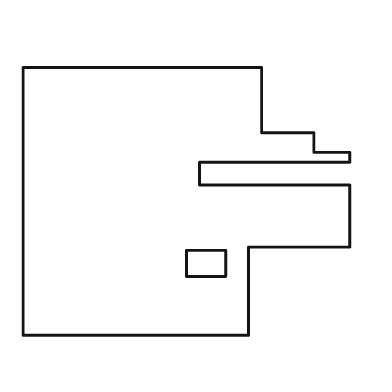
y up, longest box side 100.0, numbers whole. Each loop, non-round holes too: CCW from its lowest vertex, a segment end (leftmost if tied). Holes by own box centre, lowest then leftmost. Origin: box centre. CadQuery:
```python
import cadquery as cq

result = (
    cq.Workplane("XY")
    .moveTo(-50.0, -41.0)
    .lineTo(19.0, -41.0)
    .lineTo(19.0, -14.0)
    .lineTo(50.0, -14.0)
    .lineTo(50.0, 5.0)
    .lineTo(4.0, 5.0)
    .lineTo(4.0, 12.0)
    .lineTo(50.0, 12.0)
    .lineTo(50.0, 15.0)
    .lineTo(39.0, 15.0)
    .lineTo(39.0, 21.0)
    .lineTo(23.0, 21.0)
    .lineTo(23.0, 41.0)
    .lineTo(-50.0, 41.0)
    .close()
    .moveTo(0.0, -23.0)
    .lineTo(12.0, -23.0)
    .lineTo(12.0, -15.0)
    .lineTo(0.0, -15.0)
    .close()
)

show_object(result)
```